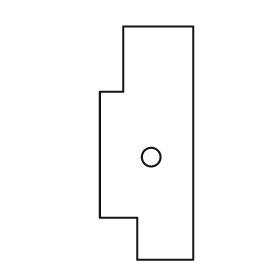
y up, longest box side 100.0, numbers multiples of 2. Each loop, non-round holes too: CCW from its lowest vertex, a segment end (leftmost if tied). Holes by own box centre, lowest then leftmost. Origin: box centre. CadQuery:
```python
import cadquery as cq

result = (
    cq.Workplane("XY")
    .moveTo(-4.0, -50.0)
    .lineTo(20.0, -50.0)
    .lineTo(20.0, 50.0)
    .lineTo(-10.0, 50.0)
    .lineTo(-10.0, 22.0)
    .lineTo(-20.0, 22.0)
    .lineTo(-20.0, -32.0)
    .lineTo(-4.0, -32.0)
    .close()
    .moveTo(2.0, -6.0)
    .circle(4.0)
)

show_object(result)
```